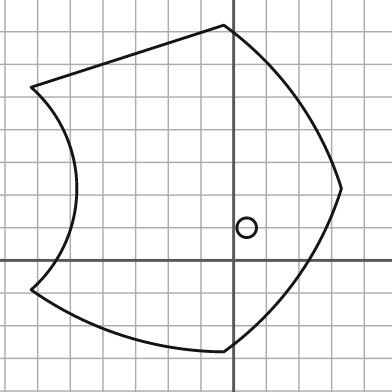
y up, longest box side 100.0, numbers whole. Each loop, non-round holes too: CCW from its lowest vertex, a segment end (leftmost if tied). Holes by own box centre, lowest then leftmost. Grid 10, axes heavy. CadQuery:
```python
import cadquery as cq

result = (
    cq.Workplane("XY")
    .moveTo(-3.0, -28.0)
    .threePointArc((19.0, -6.0), (33.0, 22.0))
    .threePointArc((19.0, 50.0), (-3.0, 72.0))
    .lineTo(-62.0, 53.0)
    .threePointArc((-48.0, 22.0), (-62.0, -9.0))
    .threePointArc((-34.0, -23.0), (-3.0, -28.0))
    .close()
    .moveTo(4.0, 10.0)
    .circle(3.0)
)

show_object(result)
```